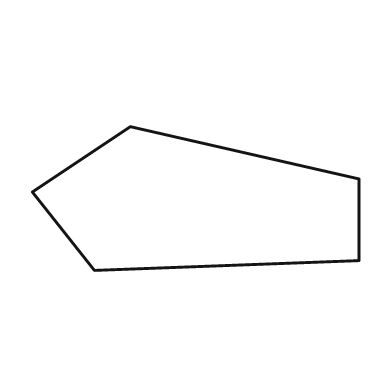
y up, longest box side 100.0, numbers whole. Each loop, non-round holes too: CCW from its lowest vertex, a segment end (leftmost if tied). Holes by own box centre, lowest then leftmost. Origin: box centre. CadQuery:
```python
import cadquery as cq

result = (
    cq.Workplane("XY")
    .moveTo(-31.0, -22.0)
    .lineTo(50.0, -19.0)
    .lineTo(50.0, 6.0)
    .lineTo(-20.0, 22.0)
    .lineTo(-50.0, 2.0)
    .close()
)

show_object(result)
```